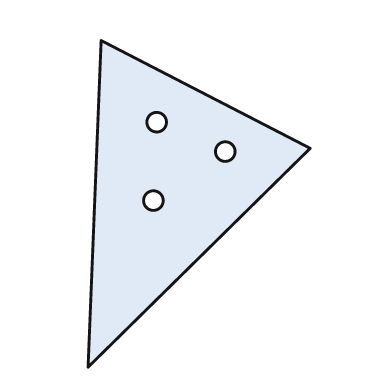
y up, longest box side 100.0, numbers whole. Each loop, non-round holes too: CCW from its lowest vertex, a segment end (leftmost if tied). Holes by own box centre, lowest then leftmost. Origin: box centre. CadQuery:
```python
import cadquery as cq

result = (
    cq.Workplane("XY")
    .moveTo(-34.0, -50.0)
    .lineTo(34.0, 17.0)
    .lineTo(-30.0, 50.0)
    .close()
    .moveTo(-14.0, 1.0)
    .circle(3.0)
    .moveTo(8.0, 16.0)
    .circle(3.0)
    .moveTo(-13.0, 25.0)
    .circle(3.0)
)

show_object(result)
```